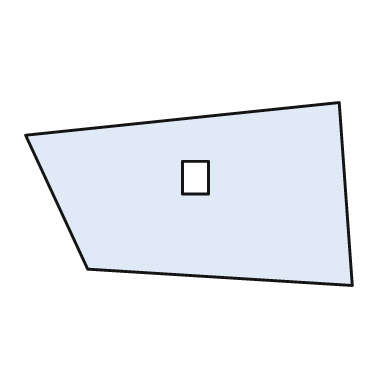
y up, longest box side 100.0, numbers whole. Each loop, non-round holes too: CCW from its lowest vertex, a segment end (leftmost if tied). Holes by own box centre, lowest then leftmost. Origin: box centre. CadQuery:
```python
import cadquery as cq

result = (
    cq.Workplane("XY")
    .moveTo(50.0, -28.0)
    .lineTo(46.0, 28.0)
    .lineTo(-50.0, 18.0)
    .lineTo(-31.0, -23.0)
    .close()
    .moveTo(-2.0, 0.0)
    .lineTo(6.0, 0.0)
    .lineTo(6.0, 10.0)
    .lineTo(-2.0, 10.0)
    .close()
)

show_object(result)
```